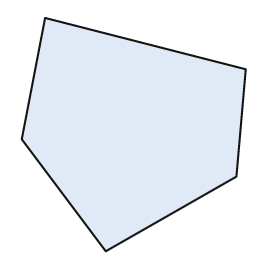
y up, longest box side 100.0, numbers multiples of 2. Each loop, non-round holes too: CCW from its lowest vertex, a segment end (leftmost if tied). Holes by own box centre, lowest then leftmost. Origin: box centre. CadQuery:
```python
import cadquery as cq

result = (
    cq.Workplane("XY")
    .moveTo(-12.0, -50.0)
    .lineTo(44.0, -18.0)
    .lineTo(48.0, 28.0)
    .lineTo(-38.0, 50.0)
    .lineTo(-48.0, -2.0)
    .close()
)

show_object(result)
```